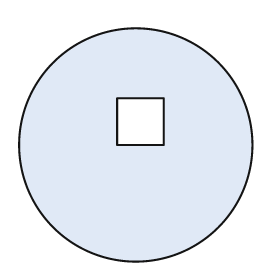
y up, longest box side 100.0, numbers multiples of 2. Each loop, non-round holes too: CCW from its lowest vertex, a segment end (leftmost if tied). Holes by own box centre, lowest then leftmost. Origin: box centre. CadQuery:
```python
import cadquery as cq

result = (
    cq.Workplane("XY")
    .moveTo(0.0, 0.0)
    .circle(50.0)
    .moveTo(-8.0, 0.0)
    .lineTo(12.0, 0.0)
    .lineTo(12.0, 20.0)
    .lineTo(-8.0, 20.0)
    .close()
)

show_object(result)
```